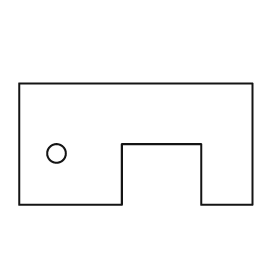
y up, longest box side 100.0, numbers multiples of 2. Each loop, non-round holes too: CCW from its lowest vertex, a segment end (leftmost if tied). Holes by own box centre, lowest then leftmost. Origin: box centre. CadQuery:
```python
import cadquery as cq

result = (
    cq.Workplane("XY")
    .moveTo(-50.0, -26.0)
    .lineTo(-6.0, -26.0)
    .lineTo(-6.0, 0.0)
    .lineTo(28.0, 0.0)
    .lineTo(28.0, -26.0)
    .lineTo(50.0, -26.0)
    .lineTo(50.0, 26.0)
    .lineTo(-50.0, 26.0)
    .close()
    .moveTo(-34.0, -4.0)
    .circle(4.0)
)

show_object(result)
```